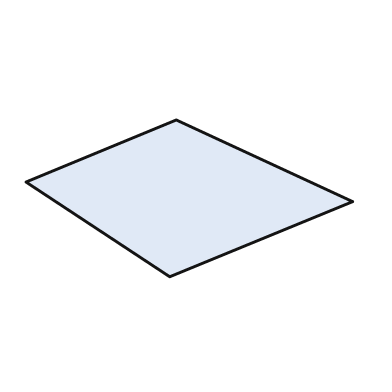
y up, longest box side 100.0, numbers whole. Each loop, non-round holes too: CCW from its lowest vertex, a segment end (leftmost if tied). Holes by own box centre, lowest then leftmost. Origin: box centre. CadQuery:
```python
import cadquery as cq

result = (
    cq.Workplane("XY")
    .moveTo(-6.0, -24.0)
    .lineTo(50.0, -1.0)
    .lineTo(-4.0, 24.0)
    .lineTo(-50.0, 5.0)
    .close()
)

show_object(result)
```